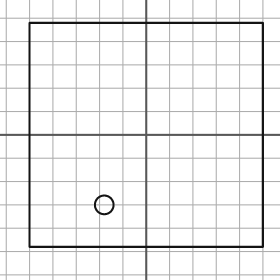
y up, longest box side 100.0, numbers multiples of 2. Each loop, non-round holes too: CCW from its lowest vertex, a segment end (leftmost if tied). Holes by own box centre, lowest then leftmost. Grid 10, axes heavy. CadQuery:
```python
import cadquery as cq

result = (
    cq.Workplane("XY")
    .moveTo(-50.0, -48.0)
    .lineTo(50.0, -48.0)
    .lineTo(50.0, 48.0)
    .lineTo(-50.0, 48.0)
    .close()
    .moveTo(-18.0, -30.0)
    .circle(4.0)
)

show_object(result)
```